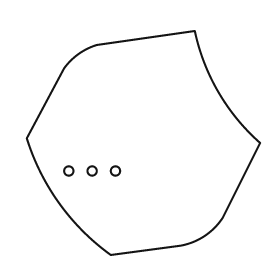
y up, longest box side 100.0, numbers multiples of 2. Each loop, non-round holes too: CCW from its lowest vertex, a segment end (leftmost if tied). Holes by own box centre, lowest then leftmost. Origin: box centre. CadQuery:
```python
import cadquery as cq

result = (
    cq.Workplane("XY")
    .moveTo(-14.0, -48.0)
    .lineTo(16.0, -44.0)
    .threePointArc((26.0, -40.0), (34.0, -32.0))
    .lineTo(50.0, 0.0)
    .threePointArc((32.0, 22.0), (22.0, 48.0))
    .lineTo(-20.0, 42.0)
    .threePointArc((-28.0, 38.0), (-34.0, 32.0))
    .lineTo(-50.0, 2.0)
    .threePointArc((-36.0, -26.0), (-14.0, -48.0))
    .close()
    .moveTo(-32.0, -12.0)
    .circle(2.0)
    .moveTo(-22.0, -12.0)
    .circle(2.0)
    .moveTo(-12.0, -12.0)
    .circle(2.0)
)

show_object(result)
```